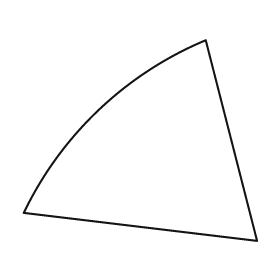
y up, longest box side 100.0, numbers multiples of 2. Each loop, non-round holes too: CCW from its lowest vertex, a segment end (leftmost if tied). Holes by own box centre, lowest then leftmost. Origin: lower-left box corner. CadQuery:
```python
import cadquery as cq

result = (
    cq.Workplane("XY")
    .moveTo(100.0, 0.0)
    .lineTo(78.0, 86.0)
    .threePointArc((32.0, 56.0), (0.0, 12.0))
    .close()
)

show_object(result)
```